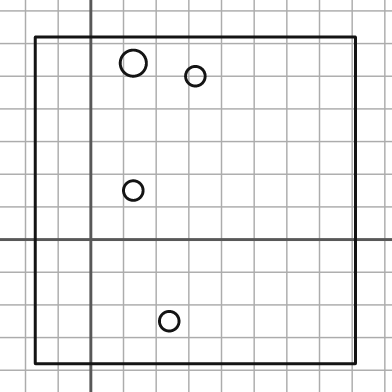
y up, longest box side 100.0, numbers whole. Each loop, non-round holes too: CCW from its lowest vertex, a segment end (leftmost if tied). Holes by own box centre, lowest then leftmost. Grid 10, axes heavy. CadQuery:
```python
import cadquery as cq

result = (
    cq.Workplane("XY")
    .moveTo(-17.0, -38.0)
    .lineTo(81.0, -38.0)
    .lineTo(81.0, 62.0)
    .lineTo(-17.0, 62.0)
    .close()
    .moveTo(24.0, -25.0)
    .circle(3.0)
    .moveTo(13.0, 15.0)
    .circle(3.0)
    .moveTo(32.0, 50.0)
    .circle(3.0)
    .moveTo(13.0, 54.0)
    .circle(4.0)
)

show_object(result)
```